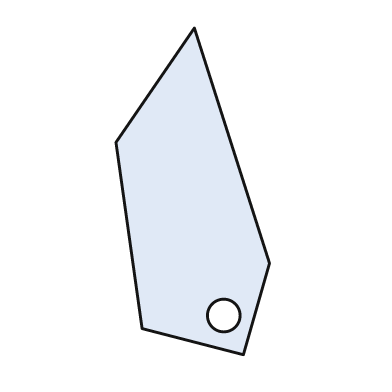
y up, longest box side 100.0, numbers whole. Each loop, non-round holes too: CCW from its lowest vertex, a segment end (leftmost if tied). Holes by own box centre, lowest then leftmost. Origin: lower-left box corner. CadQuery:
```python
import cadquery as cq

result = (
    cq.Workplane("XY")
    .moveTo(39.0, 0.0)
    .lineTo(47.0, 28.0)
    .lineTo(24.0, 100.0)
    .lineTo(0.0, 65.0)
    .lineTo(8.0, 8.0)
    .close()
    .moveTo(33.0, 12.0)
    .circle(5.0)
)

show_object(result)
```